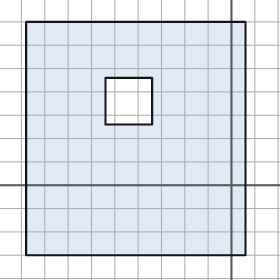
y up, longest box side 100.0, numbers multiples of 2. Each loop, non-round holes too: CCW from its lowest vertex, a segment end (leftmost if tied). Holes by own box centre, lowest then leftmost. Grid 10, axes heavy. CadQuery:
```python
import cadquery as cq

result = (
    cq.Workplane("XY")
    .moveTo(-88.0, -30.0)
    .lineTo(6.0, -30.0)
    .lineTo(6.0, 70.0)
    .lineTo(-88.0, 70.0)
    .close()
    .moveTo(-54.0, 26.0)
    .lineTo(-34.0, 26.0)
    .lineTo(-34.0, 46.0)
    .lineTo(-54.0, 46.0)
    .close()
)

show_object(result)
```